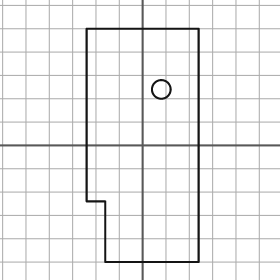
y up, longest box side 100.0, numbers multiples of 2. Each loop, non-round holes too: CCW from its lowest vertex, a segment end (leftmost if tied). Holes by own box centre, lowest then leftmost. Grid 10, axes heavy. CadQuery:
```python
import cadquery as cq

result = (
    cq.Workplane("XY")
    .moveTo(-16.0, -50.0)
    .lineTo(24.0, -50.0)
    .lineTo(24.0, 50.0)
    .lineTo(-24.0, 50.0)
    .lineTo(-24.0, -24.0)
    .lineTo(-16.0, -24.0)
    .close()
    .moveTo(8.0, 24.0)
    .circle(4.0)
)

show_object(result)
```